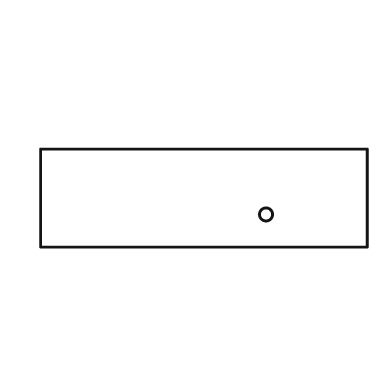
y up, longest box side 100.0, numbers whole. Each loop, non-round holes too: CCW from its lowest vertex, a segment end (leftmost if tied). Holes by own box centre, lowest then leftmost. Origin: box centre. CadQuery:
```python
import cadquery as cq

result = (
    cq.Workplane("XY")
    .moveTo(-50.0, -15.0)
    .lineTo(50.0, -15.0)
    .lineTo(50.0, 15.0)
    .lineTo(-50.0, 15.0)
    .close()
    .moveTo(19.0, -5.0)
    .circle(2.0)
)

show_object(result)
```